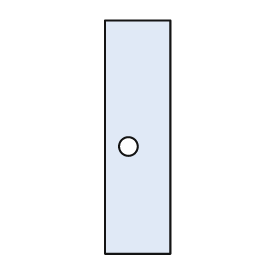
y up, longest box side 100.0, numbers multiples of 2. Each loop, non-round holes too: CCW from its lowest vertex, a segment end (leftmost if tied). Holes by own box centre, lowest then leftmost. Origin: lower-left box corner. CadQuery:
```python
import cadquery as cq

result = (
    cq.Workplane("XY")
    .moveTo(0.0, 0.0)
    .lineTo(28.0, 0.0)
    .lineTo(28.0, 100.0)
    .lineTo(0.0, 100.0)
    .close()
    .moveTo(10.0, 46.0)
    .circle(4.0)
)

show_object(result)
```